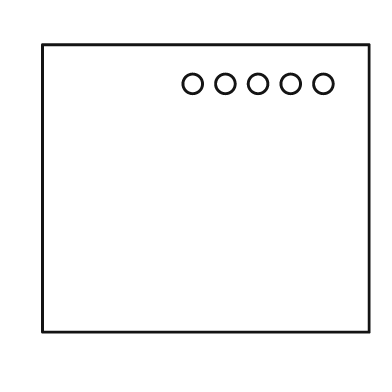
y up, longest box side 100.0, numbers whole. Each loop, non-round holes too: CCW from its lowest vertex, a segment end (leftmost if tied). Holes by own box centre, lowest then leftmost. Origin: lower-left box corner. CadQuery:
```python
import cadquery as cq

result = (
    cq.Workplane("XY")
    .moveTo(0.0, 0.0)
    .lineTo(100.0, 0.0)
    .lineTo(100.0, 88.0)
    .lineTo(0.0, 88.0)
    .close()
    .moveTo(46.0, 76.0)
    .circle(3.0)
    .moveTo(56.0, 76.0)
    .circle(3.0)
    .moveTo(66.0, 76.0)
    .circle(3.0)
    .moveTo(76.0, 76.0)
    .circle(3.0)
    .moveTo(86.0, 76.0)
    .circle(3.0)
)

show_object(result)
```